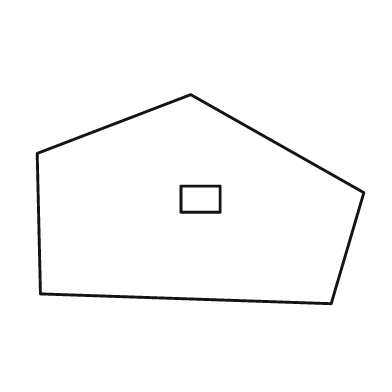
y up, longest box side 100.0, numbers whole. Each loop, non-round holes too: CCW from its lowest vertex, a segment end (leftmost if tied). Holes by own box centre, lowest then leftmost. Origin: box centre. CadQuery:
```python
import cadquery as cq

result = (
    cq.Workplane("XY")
    .moveTo(40.0, -32.0)
    .lineTo(50.0, 2.0)
    .lineTo(-3.0, 32.0)
    .lineTo(-50.0, 14.0)
    .lineTo(-49.0, -29.0)
    .close()
    .moveTo(-6.0, -4.0)
    .lineTo(6.0, -4.0)
    .lineTo(6.0, 4.0)
    .lineTo(-6.0, 4.0)
    .close()
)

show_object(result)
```